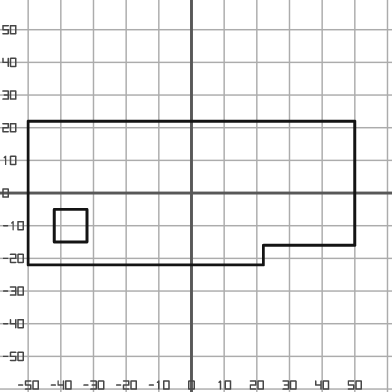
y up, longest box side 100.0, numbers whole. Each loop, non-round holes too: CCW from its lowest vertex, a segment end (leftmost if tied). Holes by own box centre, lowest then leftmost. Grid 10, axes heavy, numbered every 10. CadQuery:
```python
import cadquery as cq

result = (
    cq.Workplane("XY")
    .moveTo(-50.0, -22.0)
    .lineTo(22.0, -22.0)
    .lineTo(22.0, -16.0)
    .lineTo(50.0, -16.0)
    .lineTo(50.0, 22.0)
    .lineTo(-50.0, 22.0)
    .close()
    .moveTo(-42.0, -15.0)
    .lineTo(-32.0, -15.0)
    .lineTo(-32.0, -5.0)
    .lineTo(-42.0, -5.0)
    .close()
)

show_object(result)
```